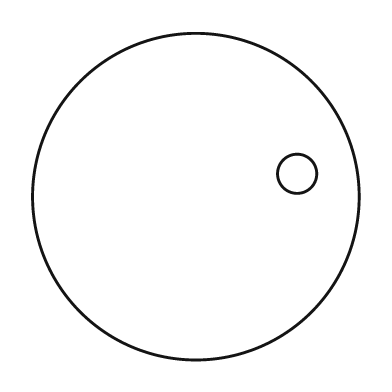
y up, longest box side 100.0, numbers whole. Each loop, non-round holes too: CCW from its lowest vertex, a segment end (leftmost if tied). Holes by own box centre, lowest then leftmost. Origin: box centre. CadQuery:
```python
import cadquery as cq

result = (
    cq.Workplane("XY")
    .moveTo(0.0, 0.0)
    .circle(50.0)
    .moveTo(31.0, 7.0)
    .circle(6.0)
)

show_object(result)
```